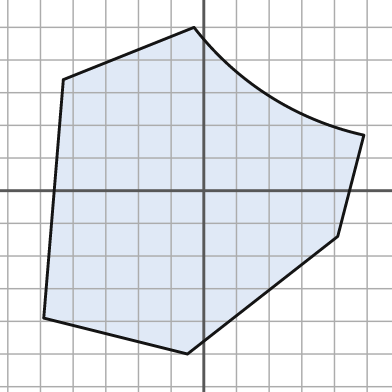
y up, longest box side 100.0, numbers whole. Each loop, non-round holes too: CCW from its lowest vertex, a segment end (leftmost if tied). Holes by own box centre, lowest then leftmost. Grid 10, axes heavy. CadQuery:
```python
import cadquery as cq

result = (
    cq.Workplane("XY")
    .moveTo(-5.0, -50.0)
    .lineTo(41.0, -14.0)
    .lineTo(49.0, 17.0)
    .threePointArc((20.0, 29.0), (-3.0, 50.0))
    .lineTo(-43.0, 34.0)
    .lineTo(-49.0, -39.0)
    .close()
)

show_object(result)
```